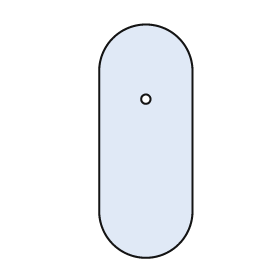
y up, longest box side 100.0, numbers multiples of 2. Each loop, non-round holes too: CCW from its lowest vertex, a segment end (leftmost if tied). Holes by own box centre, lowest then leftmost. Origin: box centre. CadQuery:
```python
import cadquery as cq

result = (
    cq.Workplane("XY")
    .moveTo(-20.0, -30.0)
    .threePointArc((0.0, -50.0), (20.0, -30.0))
    .lineTo(20.0, 30.0)
    .threePointArc((0.0, 50.0), (-20.0, 30.0))
    .close()
    .moveTo(0.0, 18.0)
    .circle(2.0)
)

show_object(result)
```